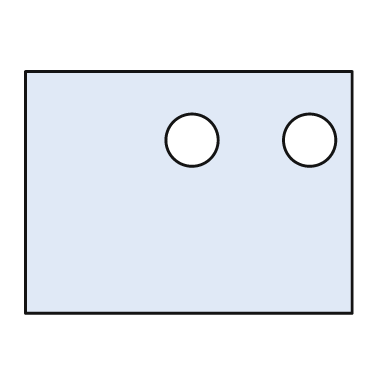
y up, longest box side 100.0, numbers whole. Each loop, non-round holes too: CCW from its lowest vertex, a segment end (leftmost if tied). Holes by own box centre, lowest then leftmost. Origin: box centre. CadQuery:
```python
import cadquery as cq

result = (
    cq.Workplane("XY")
    .moveTo(-50.0, -37.0)
    .lineTo(50.0, -37.0)
    .lineTo(50.0, 37.0)
    .lineTo(-50.0, 37.0)
    .close()
    .moveTo(1.0, 16.0)
    .circle(8.0)
    .moveTo(37.0, 16.0)
    .circle(8.0)
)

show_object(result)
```